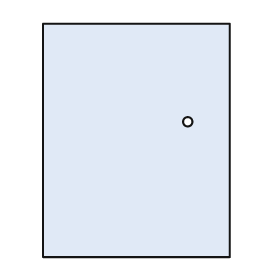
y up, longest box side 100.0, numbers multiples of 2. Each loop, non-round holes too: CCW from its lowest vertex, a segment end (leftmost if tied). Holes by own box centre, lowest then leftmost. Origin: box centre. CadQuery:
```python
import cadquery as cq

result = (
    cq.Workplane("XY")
    .moveTo(-40.0, -50.0)
    .lineTo(40.0, -50.0)
    .lineTo(40.0, 50.0)
    .lineTo(-40.0, 50.0)
    .close()
    .moveTo(22.0, 8.0)
    .circle(2.0)
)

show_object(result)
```